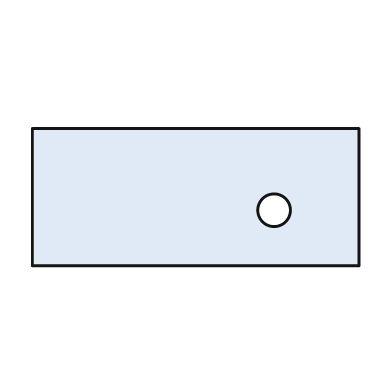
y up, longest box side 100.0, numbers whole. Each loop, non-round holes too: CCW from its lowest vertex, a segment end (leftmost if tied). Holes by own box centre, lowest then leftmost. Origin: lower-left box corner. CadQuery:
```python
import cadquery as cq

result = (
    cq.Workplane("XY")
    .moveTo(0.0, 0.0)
    .lineTo(100.0, 0.0)
    .lineTo(100.0, 42.0)
    .lineTo(0.0, 42.0)
    .close()
    .moveTo(74.0, 17.0)
    .circle(5.0)
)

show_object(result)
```